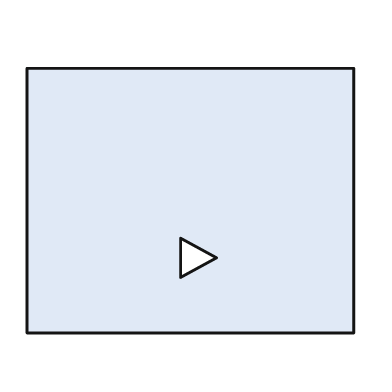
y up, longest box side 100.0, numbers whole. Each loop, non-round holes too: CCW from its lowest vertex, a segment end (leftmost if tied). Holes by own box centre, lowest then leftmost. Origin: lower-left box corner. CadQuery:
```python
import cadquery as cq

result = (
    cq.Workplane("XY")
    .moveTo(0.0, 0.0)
    .lineTo(100.0, 0.0)
    .lineTo(100.0, 81.0)
    .lineTo(0.0, 81.0)
    .close()
    .moveTo(47.0, 17.0)
    .lineTo(58.0, 23.0)
    .lineTo(47.0, 29.0)
    .close()
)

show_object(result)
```